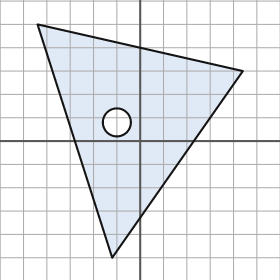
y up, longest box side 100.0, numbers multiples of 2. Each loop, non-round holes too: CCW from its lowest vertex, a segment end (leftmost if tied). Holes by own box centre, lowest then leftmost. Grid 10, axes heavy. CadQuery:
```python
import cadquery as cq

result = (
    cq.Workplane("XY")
    .moveTo(-12.0, -50.0)
    .lineTo(44.0, 30.0)
    .lineTo(-44.0, 50.0)
    .close()
    .moveTo(-10.0, 8.0)
    .circle(6.0)
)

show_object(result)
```